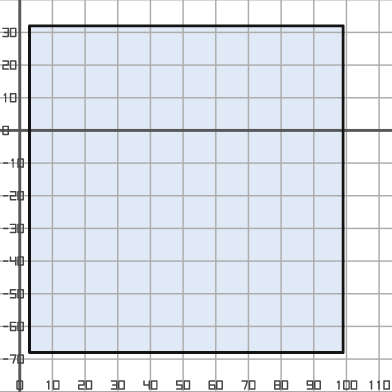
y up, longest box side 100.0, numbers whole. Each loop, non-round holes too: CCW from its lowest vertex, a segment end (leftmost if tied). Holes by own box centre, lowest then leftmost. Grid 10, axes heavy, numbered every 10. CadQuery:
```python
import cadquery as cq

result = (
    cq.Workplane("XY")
    .moveTo(3.0, -68.0)
    .lineTo(99.0, -68.0)
    .lineTo(99.0, 32.0)
    .lineTo(3.0, 32.0)
    .close()
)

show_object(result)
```